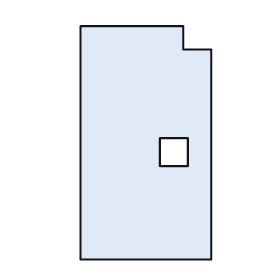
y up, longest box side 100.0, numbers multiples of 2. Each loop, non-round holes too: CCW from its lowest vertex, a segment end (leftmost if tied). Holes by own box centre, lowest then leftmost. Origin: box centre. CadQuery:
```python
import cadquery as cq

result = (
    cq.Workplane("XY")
    .moveTo(-28.0, -50.0)
    .lineTo(28.0, -50.0)
    .lineTo(28.0, 40.0)
    .lineTo(16.0, 40.0)
    .lineTo(16.0, 50.0)
    .lineTo(-28.0, 50.0)
    .close()
    .moveTo(6.0, -10.0)
    .lineTo(18.0, -10.0)
    .lineTo(18.0, 2.0)
    .lineTo(6.0, 2.0)
    .close()
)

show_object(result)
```